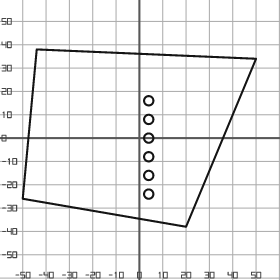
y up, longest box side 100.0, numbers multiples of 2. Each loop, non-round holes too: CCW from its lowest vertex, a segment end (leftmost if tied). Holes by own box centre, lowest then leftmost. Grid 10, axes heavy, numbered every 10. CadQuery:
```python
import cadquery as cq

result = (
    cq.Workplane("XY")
    .moveTo(20.0, -38.0)
    .lineTo(50.0, 34.0)
    .lineTo(-44.0, 38.0)
    .lineTo(-50.0, -26.0)
    .close()
    .moveTo(4.0, -24.0)
    .circle(2.0)
    .moveTo(4.0, -16.0)
    .circle(2.0)
    .moveTo(4.0, -8.0)
    .circle(2.0)
    .moveTo(4.0, 0.0)
    .circle(2.0)
    .moveTo(4.0, 8.0)
    .circle(2.0)
    .moveTo(4.0, 16.0)
    .circle(2.0)
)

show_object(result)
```